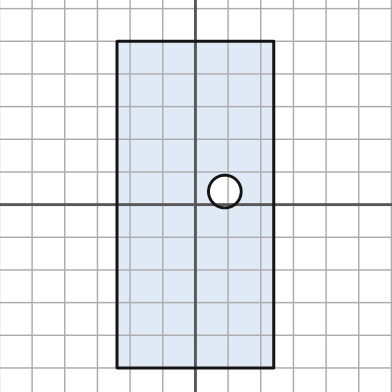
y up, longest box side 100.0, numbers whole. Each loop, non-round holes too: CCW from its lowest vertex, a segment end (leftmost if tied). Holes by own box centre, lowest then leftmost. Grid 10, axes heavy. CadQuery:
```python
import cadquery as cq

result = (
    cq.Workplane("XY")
    .moveTo(-24.0, -50.0)
    .lineTo(24.0, -50.0)
    .lineTo(24.0, 50.0)
    .lineTo(-24.0, 50.0)
    .close()
    .moveTo(9.0, 4.0)
    .circle(5.0)
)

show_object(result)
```